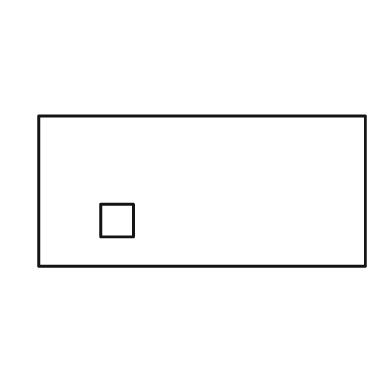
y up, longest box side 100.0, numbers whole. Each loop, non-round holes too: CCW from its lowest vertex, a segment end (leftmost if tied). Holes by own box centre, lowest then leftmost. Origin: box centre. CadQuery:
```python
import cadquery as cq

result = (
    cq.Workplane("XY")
    .moveTo(-50.0, -23.0)
    .lineTo(50.0, -23.0)
    .lineTo(50.0, 23.0)
    .lineTo(-50.0, 23.0)
    .close()
    .moveTo(-31.0, -14.0)
    .lineTo(-21.0, -14.0)
    .lineTo(-21.0, -4.0)
    .lineTo(-31.0, -4.0)
    .close()
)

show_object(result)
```